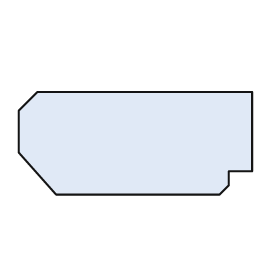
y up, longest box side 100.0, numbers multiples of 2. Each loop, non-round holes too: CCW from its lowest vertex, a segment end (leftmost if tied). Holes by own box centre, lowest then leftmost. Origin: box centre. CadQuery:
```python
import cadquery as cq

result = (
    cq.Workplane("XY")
    .moveTo(-34.0, -22.0)
    .lineTo(36.0, -22.0)
    .lineTo(40.0, -18.0)
    .lineTo(40.0, -12.0)
    .lineTo(50.0, -12.0)
    .lineTo(50.0, 22.0)
    .lineTo(-42.0, 22.0)
    .lineTo(-50.0, 14.0)
    .lineTo(-50.0, -4.0)
    .close()
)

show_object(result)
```